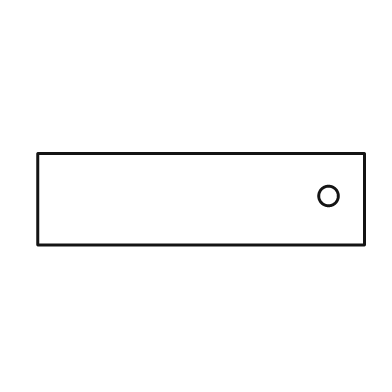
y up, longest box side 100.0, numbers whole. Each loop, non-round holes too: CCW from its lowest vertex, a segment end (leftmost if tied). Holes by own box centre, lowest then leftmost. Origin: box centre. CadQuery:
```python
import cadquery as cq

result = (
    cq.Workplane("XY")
    .moveTo(-50.0, -14.0)
    .lineTo(50.0, -14.0)
    .lineTo(50.0, 14.0)
    .lineTo(-50.0, 14.0)
    .close()
    .moveTo(39.0, 1.0)
    .circle(3.0)
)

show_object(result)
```